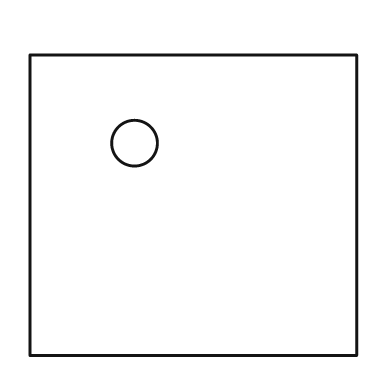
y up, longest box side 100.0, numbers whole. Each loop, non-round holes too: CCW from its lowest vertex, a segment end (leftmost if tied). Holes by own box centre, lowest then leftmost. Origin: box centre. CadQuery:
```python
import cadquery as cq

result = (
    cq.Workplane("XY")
    .moveTo(-50.0, -46.0)
    .lineTo(50.0, -46.0)
    .lineTo(50.0, 46.0)
    .lineTo(-50.0, 46.0)
    .close()
    .moveTo(-18.0, 19.0)
    .circle(7.0)
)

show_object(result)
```